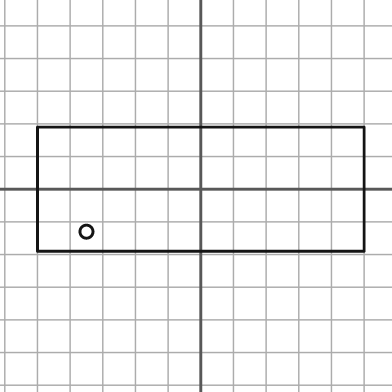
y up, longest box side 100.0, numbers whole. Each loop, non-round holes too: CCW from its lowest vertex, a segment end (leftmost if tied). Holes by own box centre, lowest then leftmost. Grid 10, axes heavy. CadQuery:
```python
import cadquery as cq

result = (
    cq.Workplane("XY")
    .moveTo(-50.0, -19.0)
    .lineTo(50.0, -19.0)
    .lineTo(50.0, 19.0)
    .lineTo(-50.0, 19.0)
    .close()
    .moveTo(-35.0, -13.0)
    .circle(2.0)
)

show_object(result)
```